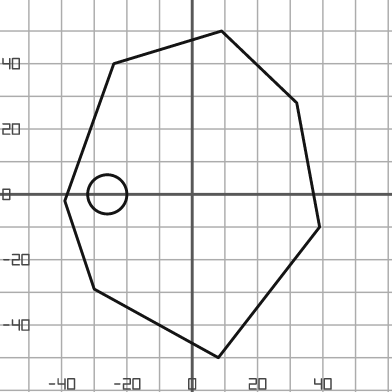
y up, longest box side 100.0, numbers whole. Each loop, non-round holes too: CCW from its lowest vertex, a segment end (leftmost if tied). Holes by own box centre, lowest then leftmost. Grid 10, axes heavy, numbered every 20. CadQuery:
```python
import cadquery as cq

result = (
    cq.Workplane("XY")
    .moveTo(8.0, -50.0)
    .lineTo(39.0, -10.0)
    .lineTo(32.0, 28.0)
    .lineTo(9.0, 50.0)
    .lineTo(-24.0, 40.0)
    .lineTo(-39.0, -2.0)
    .lineTo(-30.0, -29.0)
    .close()
    .moveTo(-26.0, 0.0)
    .circle(6.0)
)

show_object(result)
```